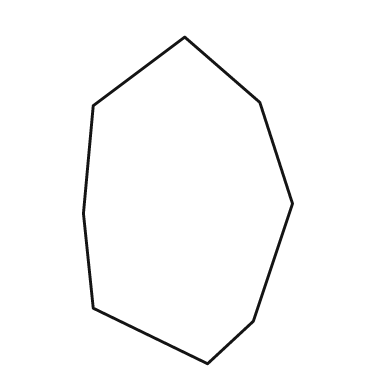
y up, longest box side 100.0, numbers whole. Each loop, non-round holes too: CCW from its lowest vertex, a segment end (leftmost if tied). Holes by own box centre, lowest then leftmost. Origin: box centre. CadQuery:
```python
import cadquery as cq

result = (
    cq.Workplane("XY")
    .moveTo(6.0, -50.0)
    .lineTo(20.0, -37.0)
    .lineTo(32.0, -1.0)
    .lineTo(22.0, 30.0)
    .lineTo(-1.0, 50.0)
    .lineTo(-29.0, 29.0)
    .lineTo(-32.0, -4.0)
    .lineTo(-29.0, -33.0)
    .close()
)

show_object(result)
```